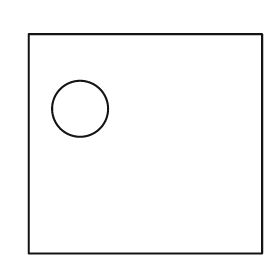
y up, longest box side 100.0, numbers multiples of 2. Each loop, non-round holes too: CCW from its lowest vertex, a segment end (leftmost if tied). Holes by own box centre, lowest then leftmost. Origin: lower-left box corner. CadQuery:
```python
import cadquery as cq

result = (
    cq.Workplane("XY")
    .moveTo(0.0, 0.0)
    .lineTo(100.0, 0.0)
    .lineTo(100.0, 94.0)
    .lineTo(0.0, 94.0)
    .close()
    .moveTo(22.0, 62.0)
    .circle(12.0)
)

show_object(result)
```